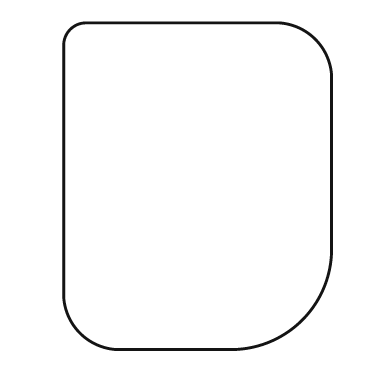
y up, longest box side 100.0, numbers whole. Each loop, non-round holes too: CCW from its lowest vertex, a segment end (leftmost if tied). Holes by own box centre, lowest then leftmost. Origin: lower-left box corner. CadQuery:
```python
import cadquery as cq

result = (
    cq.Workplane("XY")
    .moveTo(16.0, 0.0)
    .lineTo(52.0, 0.0)
    .threePointArc((73.0, 9.0), (82.0, 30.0))
    .lineTo(82.0, 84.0)
    .threePointArc((77.0, 95.0), (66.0, 100.0))
    .lineTo(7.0, 100.0)
    .threePointArc((2.0, 98.0), (0.0, 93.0))
    .lineTo(0.0, 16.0)
    .threePointArc((5.0, 5.0), (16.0, 0.0))
    .close()
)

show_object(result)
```